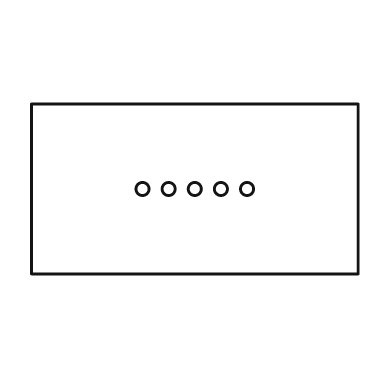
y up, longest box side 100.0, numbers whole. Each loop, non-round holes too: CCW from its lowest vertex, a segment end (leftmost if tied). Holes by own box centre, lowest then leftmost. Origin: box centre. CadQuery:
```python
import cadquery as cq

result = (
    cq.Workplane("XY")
    .moveTo(-50.0, -26.0)
    .lineTo(50.0, -26.0)
    .lineTo(50.0, 26.0)
    .lineTo(-50.0, 26.0)
    .close()
    .moveTo(-16.0, 0.0)
    .circle(2.0)
    .moveTo(-8.0, 0.0)
    .circle(2.0)
    .moveTo(0.0, 0.0)
    .circle(2.0)
    .moveTo(8.0, 0.0)
    .circle(2.0)
    .moveTo(16.0, 0.0)
    .circle(2.0)
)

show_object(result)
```